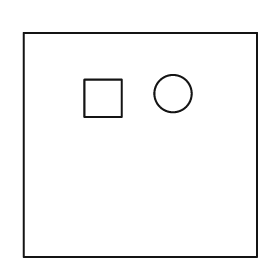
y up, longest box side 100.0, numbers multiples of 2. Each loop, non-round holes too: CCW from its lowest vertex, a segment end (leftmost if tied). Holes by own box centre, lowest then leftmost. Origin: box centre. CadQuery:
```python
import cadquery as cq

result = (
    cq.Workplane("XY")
    .moveTo(-50.0, -48.0)
    .lineTo(50.0, -48.0)
    .lineTo(50.0, 48.0)
    .lineTo(-50.0, 48.0)
    .close()
    .moveTo(-24.0, 12.0)
    .lineTo(-8.0, 12.0)
    .lineTo(-8.0, 28.0)
    .lineTo(-24.0, 28.0)
    .close()
    .moveTo(14.0, 22.0)
    .circle(8.0)
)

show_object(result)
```